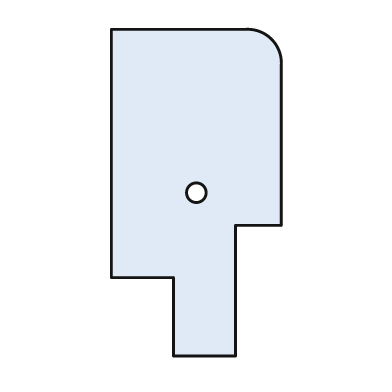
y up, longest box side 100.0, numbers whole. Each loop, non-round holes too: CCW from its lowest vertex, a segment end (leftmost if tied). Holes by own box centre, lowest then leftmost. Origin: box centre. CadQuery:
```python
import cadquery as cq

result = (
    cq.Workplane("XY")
    .moveTo(-7.0, -50.0)
    .lineTo(12.0, -50.0)
    .lineTo(12.0, -10.0)
    .lineTo(26.0, -10.0)
    .lineTo(26.0, 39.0)
    .threePointArc((23.0, 47.0), (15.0, 50.0))
    .lineTo(-26.0, 50.0)
    .lineTo(-26.0, -26.0)
    .lineTo(-7.0, -26.0)
    .close()
    .moveTo(0.0, 0.0)
    .circle(3.0)
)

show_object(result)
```